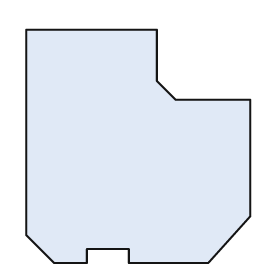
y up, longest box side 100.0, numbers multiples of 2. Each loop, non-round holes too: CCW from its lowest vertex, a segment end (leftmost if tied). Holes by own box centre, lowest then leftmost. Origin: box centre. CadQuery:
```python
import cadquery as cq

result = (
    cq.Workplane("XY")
    .moveTo(-36.0, -50.0)
    .lineTo(-22.0, -50.0)
    .lineTo(-22.0, -44.0)
    .lineTo(-4.0, -44.0)
    .lineTo(-4.0, -50.0)
    .lineTo(30.0, -50.0)
    .lineTo(48.0, -30.0)
    .lineTo(48.0, 20.0)
    .lineTo(16.0, 20.0)
    .lineTo(8.0, 28.0)
    .lineTo(8.0, 50.0)
    .lineTo(-48.0, 50.0)
    .lineTo(-48.0, -38.0)
    .close()
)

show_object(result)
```